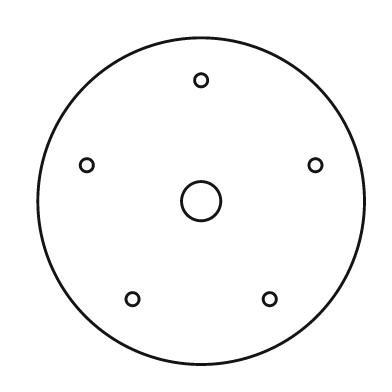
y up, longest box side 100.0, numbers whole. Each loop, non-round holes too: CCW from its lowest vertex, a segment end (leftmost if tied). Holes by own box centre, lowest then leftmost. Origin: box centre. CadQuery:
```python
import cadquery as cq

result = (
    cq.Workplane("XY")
    .moveTo(0.0, 0.0)
    .circle(50.0)
    .moveTo(-21.0, -30.0)
    .circle(2.0)
    .moveTo(21.0, -30.0)
    .circle(2.0)
    .moveTo(0.0, 0.0)
    .circle(6.0)
    .moveTo(-35.0, 11.0)
    .circle(2.0)
    .moveTo(35.0, 11.0)
    .circle(2.0)
    .moveTo(0.0, 37.0)
    .circle(2.0)
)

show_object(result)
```